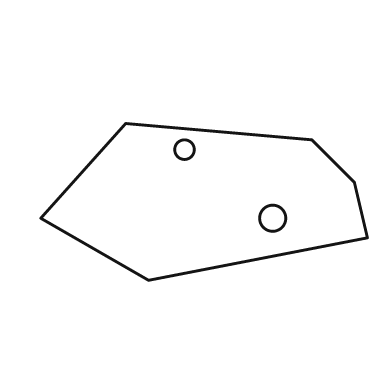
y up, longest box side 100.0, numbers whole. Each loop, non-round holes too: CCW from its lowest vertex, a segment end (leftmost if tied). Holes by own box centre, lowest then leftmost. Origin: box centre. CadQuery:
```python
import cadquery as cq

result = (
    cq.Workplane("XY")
    .moveTo(-17.0, -24.0)
    .lineTo(50.0, -11.0)
    .lineTo(46.0, 6.0)
    .lineTo(33.0, 19.0)
    .lineTo(-24.0, 24.0)
    .lineTo(-50.0, -5.0)
    .close()
    .moveTo(21.0, -5.0)
    .circle(4.0)
    .moveTo(-6.0, 16.0)
    .circle(3.0)
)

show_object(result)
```